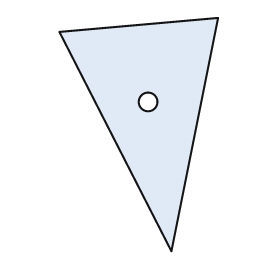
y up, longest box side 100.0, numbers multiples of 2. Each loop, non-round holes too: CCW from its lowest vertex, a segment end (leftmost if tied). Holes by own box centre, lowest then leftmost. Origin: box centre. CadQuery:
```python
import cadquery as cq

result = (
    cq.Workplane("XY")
    .moveTo(14.0, -50.0)
    .lineTo(34.0, 50.0)
    .lineTo(-34.0, 44.0)
    .close()
    .moveTo(4.0, 14.0)
    .circle(4.0)
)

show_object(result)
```